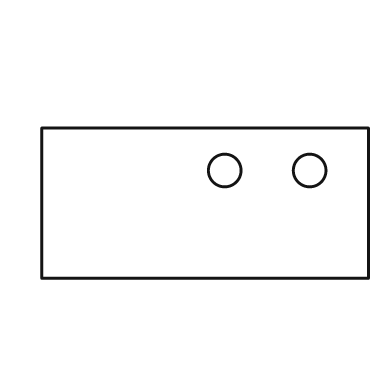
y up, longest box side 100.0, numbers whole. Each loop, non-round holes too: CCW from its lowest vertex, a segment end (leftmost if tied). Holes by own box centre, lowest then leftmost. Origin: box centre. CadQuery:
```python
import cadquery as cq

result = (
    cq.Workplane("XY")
    .moveTo(-50.0, -23.0)
    .lineTo(50.0, -23.0)
    .lineTo(50.0, 23.0)
    .lineTo(-50.0, 23.0)
    .close()
    .moveTo(6.0, 10.0)
    .circle(5.0)
    .moveTo(32.0, 10.0)
    .circle(5.0)
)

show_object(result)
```